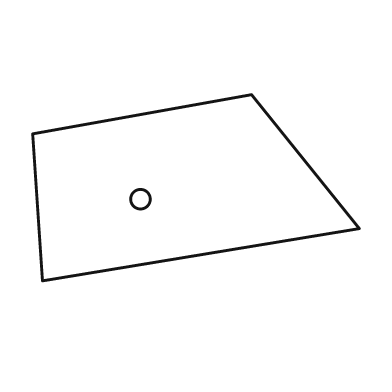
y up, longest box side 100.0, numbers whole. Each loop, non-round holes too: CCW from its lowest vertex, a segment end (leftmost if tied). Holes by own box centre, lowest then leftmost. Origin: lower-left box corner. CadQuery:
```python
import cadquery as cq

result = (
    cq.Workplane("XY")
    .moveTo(3.0, 0.0)
    .lineTo(100.0, 16.0)
    .lineTo(67.0, 57.0)
    .lineTo(0.0, 45.0)
    .close()
    .moveTo(33.0, 25.0)
    .circle(3.0)
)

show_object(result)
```